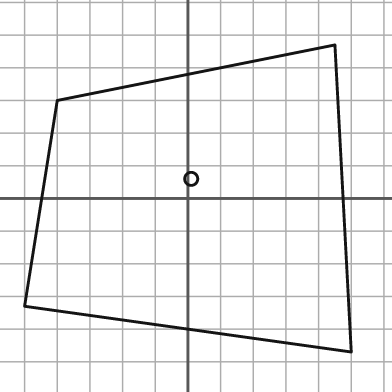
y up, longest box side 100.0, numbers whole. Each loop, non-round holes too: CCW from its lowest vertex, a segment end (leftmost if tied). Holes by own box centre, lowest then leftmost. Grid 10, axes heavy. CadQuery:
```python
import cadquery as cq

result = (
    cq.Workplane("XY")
    .moveTo(50.0, -47.0)
    .lineTo(45.0, 47.0)
    .lineTo(-40.0, 30.0)
    .lineTo(-50.0, -33.0)
    .close()
    .moveTo(1.0, 6.0)
    .circle(2.0)
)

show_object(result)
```